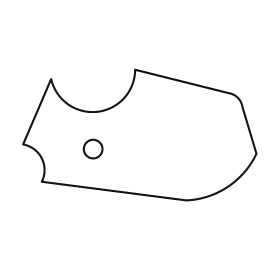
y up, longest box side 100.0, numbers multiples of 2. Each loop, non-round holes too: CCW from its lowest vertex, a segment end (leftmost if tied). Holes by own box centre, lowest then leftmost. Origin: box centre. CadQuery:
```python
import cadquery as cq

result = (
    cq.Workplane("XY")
    .moveTo(20.0, -28.0)
    .threePointArc((38.0, -22.0), (50.0, -8.0))
    .lineTo(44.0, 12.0)
    .threePointArc((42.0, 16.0), (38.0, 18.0))
    .lineTo(-2.0, 28.0)
    .threePointArc((-18.0, 10.0), (-38.0, 24.0))
    .lineTo(-50.0, -4.0)
    .threePointArc((-42.0, -10.0), (-42.0, -20.0))
    .close()
    .moveTo(-20.0, -6.0)
    .circle(4.0)
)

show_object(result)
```